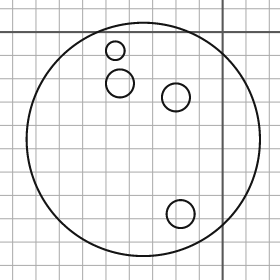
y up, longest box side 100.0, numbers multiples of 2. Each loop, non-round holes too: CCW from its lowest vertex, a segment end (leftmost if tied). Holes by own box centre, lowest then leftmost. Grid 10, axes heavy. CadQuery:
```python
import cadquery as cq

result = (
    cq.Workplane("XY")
    .moveTo(-34.0, -46.0)
    .circle(50.0)
    .moveTo(-18.0, -78.0)
    .circle(6.0)
    .moveTo(-20.0, -28.0)
    .circle(6.0)
    .moveTo(-44.0, -22.0)
    .circle(6.0)
    .moveTo(-46.0, -8.0)
    .circle(4.0)
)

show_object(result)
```